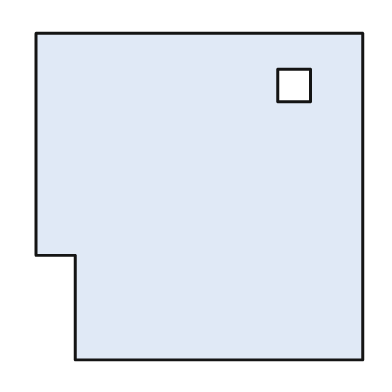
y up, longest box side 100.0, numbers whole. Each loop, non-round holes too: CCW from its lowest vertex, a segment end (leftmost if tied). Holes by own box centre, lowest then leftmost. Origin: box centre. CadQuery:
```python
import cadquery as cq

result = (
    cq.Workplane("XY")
    .moveTo(-38.0, -50.0)
    .lineTo(50.0, -50.0)
    .lineTo(50.0, 50.0)
    .lineTo(-50.0, 50.0)
    .lineTo(-50.0, -18.0)
    .lineTo(-38.0, -18.0)
    .close()
    .moveTo(24.0, 29.0)
    .lineTo(34.0, 29.0)
    .lineTo(34.0, 39.0)
    .lineTo(24.0, 39.0)
    .close()
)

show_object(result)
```